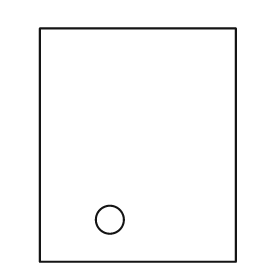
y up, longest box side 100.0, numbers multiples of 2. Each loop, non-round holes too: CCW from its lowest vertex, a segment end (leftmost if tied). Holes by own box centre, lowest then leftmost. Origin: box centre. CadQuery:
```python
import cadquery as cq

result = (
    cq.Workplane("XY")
    .moveTo(-42.0, -50.0)
    .lineTo(42.0, -50.0)
    .lineTo(42.0, 50.0)
    .lineTo(-42.0, 50.0)
    .close()
    .moveTo(-12.0, -32.0)
    .circle(6.0)
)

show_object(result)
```